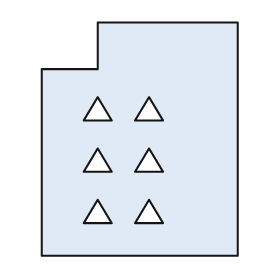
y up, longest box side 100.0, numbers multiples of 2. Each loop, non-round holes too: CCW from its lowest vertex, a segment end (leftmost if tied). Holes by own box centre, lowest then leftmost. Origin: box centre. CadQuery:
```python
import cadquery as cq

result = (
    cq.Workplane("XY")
    .moveTo(-42.0, -50.0)
    .lineTo(42.0, -50.0)
    .lineTo(42.0, 50.0)
    .lineTo(-18.0, 50.0)
    .lineTo(-18.0, 30.0)
    .lineTo(-42.0, 30.0)
    .close()
    .moveTo(-24.0, -36.0)
    .lineTo(-12.0, -36.0)
    .lineTo(-18.0, -26.0)
    .close()
    .moveTo(-2.0, -36.0)
    .lineTo(10.0, -36.0)
    .lineTo(4.0, -26.0)
    .close()
    .moveTo(-24.0, -14.0)
    .lineTo(-12.0, -14.0)
    .lineTo(-18.0, -4.0)
    .close()
    .moveTo(-2.0, -14.0)
    .lineTo(10.0, -14.0)
    .lineTo(4.0, -4.0)
    .close()
    .moveTo(-24.0, 8.0)
    .lineTo(-12.0, 8.0)
    .lineTo(-18.0, 18.0)
    .close()
    .moveTo(-2.0, 8.0)
    .lineTo(10.0, 8.0)
    .lineTo(4.0, 18.0)
    .close()
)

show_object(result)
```